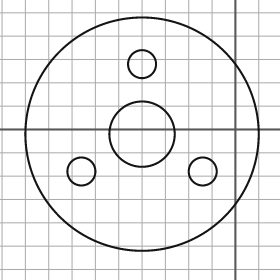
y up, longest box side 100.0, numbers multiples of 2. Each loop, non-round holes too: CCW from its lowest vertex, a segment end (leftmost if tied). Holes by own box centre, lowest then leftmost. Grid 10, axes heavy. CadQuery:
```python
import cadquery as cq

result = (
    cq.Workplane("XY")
    .moveTo(-40.0, -2.0)
    .circle(50.0)
    .moveTo(-66.0, -18.0)
    .circle(6.0)
    .moveTo(-14.0, -18.0)
    .circle(6.0)
    .moveTo(-40.0, -2.0)
    .circle(14.0)
    .moveTo(-40.0, 28.0)
    .circle(6.0)
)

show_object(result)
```